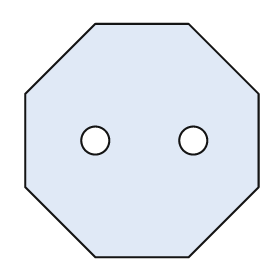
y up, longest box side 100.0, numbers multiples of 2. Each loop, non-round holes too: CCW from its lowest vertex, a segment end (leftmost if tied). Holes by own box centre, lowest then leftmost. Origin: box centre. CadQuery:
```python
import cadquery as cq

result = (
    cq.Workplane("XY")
    .moveTo(-20.0, -50.0)
    .lineTo(20.0, -50.0)
    .lineTo(50.0, -20.0)
    .lineTo(50.0, 20.0)
    .lineTo(20.0, 50.0)
    .lineTo(-20.0, 50.0)
    .lineTo(-50.0, 20.0)
    .lineTo(-50.0, -20.0)
    .close()
    .moveTo(-20.0, 0.0)
    .circle(6.0)
    .moveTo(22.0, 0.0)
    .circle(6.0)
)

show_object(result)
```